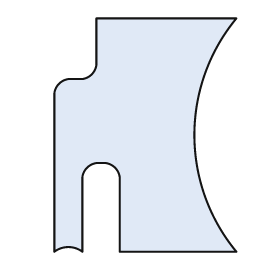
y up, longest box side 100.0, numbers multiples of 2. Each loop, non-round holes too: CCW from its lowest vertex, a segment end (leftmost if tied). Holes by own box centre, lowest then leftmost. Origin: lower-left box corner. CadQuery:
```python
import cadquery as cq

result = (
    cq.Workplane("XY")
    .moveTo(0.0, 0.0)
    .threePointArc((6.0, 2.0), (12.0, 0.0))
    .lineTo(12.0, 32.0)
    .threePointArc((14.0, 36.0), (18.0, 38.0))
    .lineTo(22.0, 38.0)
    .threePointArc((26.0, 36.0), (28.0, 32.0))
    .lineTo(28.0, 0.0)
    .lineTo(78.0, 0.0)
    .threePointArc((60.0, 50.0), (78.0, 100.0))
    .lineTo(18.0, 100.0)
    .lineTo(18.0, 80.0)
    .threePointArc((16.0, 76.0), (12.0, 74.0))
    .lineTo(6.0, 74.0)
    .threePointArc((2.0, 72.0), (0.0, 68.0))
    .close()
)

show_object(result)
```